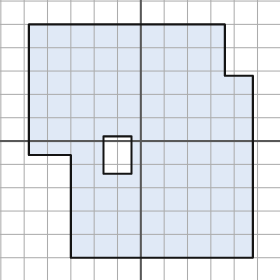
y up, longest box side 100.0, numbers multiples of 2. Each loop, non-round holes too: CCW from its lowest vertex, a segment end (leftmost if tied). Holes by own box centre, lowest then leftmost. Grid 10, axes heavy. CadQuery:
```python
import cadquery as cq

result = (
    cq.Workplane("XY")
    .moveTo(-30.0, -50.0)
    .lineTo(48.0, -50.0)
    .lineTo(48.0, 28.0)
    .lineTo(36.0, 28.0)
    .lineTo(36.0, 50.0)
    .lineTo(-48.0, 50.0)
    .lineTo(-48.0, -6.0)
    .lineTo(-30.0, -6.0)
    .close()
    .moveTo(-16.0, -14.0)
    .lineTo(-4.0, -14.0)
    .lineTo(-4.0, 2.0)
    .lineTo(-16.0, 2.0)
    .close()
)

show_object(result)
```